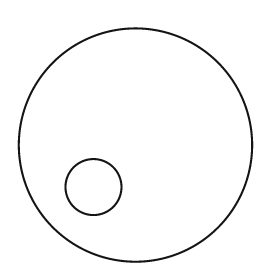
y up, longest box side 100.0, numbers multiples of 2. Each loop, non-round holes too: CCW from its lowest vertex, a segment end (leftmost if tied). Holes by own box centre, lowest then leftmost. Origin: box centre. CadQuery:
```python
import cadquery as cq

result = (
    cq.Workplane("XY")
    .moveTo(0.0, 0.0)
    .circle(50.0)
    .moveTo(-18.0, -18.0)
    .circle(12.0)
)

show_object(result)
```